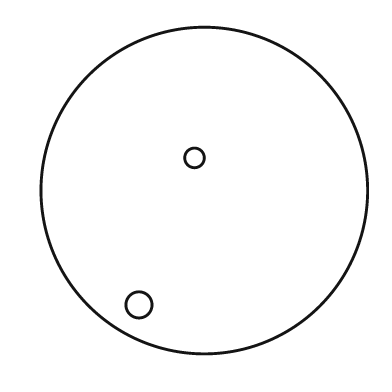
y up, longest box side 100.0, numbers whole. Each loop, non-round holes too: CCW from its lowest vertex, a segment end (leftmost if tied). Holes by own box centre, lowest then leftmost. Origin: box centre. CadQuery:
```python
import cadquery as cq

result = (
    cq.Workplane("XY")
    .moveTo(0.0, 0.0)
    .circle(50.0)
    .moveTo(-20.0, -35.0)
    .circle(4.0)
    .moveTo(-3.0, 10.0)
    .circle(3.0)
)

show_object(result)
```